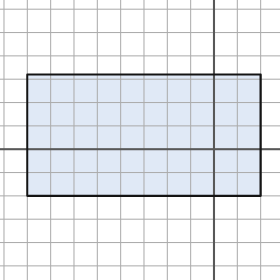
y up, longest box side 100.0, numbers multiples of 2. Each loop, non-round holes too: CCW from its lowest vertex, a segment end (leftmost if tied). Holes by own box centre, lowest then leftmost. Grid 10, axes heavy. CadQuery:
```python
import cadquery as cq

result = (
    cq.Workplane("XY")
    .moveTo(-80.0, -20.0)
    .lineTo(20.0, -20.0)
    .lineTo(20.0, 32.0)
    .lineTo(-80.0, 32.0)
    .close()
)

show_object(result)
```